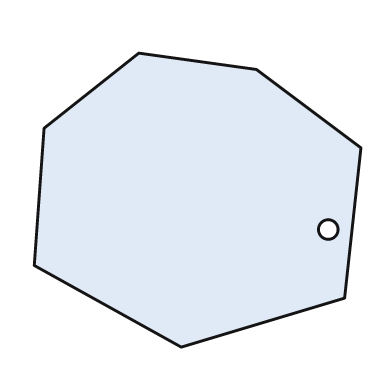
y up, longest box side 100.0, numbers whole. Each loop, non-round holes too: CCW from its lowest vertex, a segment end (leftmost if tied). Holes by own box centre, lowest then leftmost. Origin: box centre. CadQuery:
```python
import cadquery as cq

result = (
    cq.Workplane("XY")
    .moveTo(-5.0, -45.0)
    .lineTo(45.0, -30.0)
    .lineTo(50.0, 16.0)
    .lineTo(18.0, 40.0)
    .lineTo(-18.0, 45.0)
    .lineTo(-47.0, 22.0)
    .lineTo(-50.0, -20.0)
    .close()
    .moveTo(40.0, -9.0)
    .circle(3.0)
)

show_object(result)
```